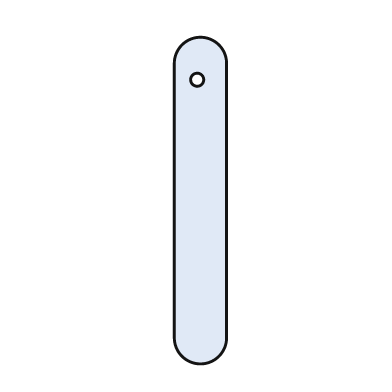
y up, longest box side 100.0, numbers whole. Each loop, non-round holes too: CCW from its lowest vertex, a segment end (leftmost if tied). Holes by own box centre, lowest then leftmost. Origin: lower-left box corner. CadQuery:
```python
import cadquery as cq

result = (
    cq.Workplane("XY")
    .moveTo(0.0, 8.0)
    .threePointArc((8.0, 0.0), (16.0, 8.0))
    .lineTo(16.0, 92.0)
    .threePointArc((8.0, 100.0), (0.0, 92.0))
    .close()
    .moveTo(7.0, 87.0)
    .circle(2.0)
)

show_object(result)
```